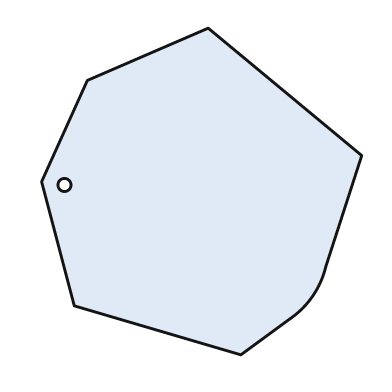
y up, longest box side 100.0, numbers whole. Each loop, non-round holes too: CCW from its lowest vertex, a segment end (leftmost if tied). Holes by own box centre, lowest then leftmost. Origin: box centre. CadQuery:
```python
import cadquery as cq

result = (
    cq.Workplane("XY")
    .moveTo(12.0, -50.0)
    .lineTo(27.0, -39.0)
    .threePointArc((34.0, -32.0), (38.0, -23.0))
    .lineTo(49.0, 11.0)
    .lineTo(2.0, 50.0)
    .lineTo(-35.0, 34.0)
    .lineTo(-49.0, 3.0)
    .lineTo(-39.0, -35.0)
    .close()
    .moveTo(-42.0, 2.0)
    .circle(2.0)
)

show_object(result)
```